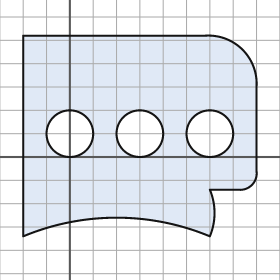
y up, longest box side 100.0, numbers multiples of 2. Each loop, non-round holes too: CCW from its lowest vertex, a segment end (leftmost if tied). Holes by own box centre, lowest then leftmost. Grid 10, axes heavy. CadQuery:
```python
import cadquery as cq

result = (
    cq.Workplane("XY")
    .moveTo(-20.0, -34.0)
    .threePointArc((20.0, -26.0), (60.0, -34.0))
    .threePointArc((62.0, -24.0), (60.0, -14.0))
    .lineTo(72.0, -14.0)
    .threePointArc((78.0, -12.0), (80.0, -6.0))
    .lineTo(80.0, 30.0)
    .threePointArc((74.0, 46.0), (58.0, 52.0))
    .lineTo(-20.0, 52.0)
    .close()
    .moveTo(0.0, 10.0)
    .circle(10.0)
    .moveTo(30.0, 10.0)
    .circle(10.0)
    .moveTo(60.0, 10.0)
    .circle(10.0)
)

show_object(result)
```